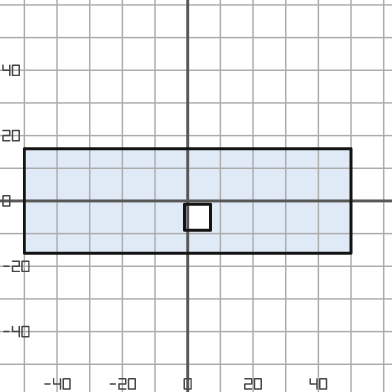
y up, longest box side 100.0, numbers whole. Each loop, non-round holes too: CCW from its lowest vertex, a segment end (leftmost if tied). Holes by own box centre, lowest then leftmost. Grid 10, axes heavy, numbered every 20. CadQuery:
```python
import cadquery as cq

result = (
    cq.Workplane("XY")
    .moveTo(-50.0, -16.0)
    .lineTo(50.0, -16.0)
    .lineTo(50.0, 16.0)
    .lineTo(-50.0, 16.0)
    .close()
    .moveTo(-1.0, -9.0)
    .lineTo(7.0, -9.0)
    .lineTo(7.0, -1.0)
    .lineTo(-1.0, -1.0)
    .close()
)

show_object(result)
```